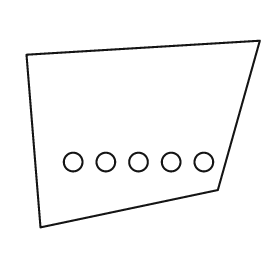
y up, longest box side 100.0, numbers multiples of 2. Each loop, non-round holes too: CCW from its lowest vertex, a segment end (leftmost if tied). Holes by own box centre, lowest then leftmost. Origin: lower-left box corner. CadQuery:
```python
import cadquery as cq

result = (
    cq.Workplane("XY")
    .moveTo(6.0, 0.0)
    .lineTo(82.0, 16.0)
    .lineTo(100.0, 80.0)
    .lineTo(0.0, 74.0)
    .close()
    .moveTo(20.0, 28.0)
    .circle(4.0)
    .moveTo(34.0, 28.0)
    .circle(4.0)
    .moveTo(48.0, 28.0)
    .circle(4.0)
    .moveTo(62.0, 28.0)
    .circle(4.0)
    .moveTo(76.0, 28.0)
    .circle(4.0)
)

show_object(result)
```